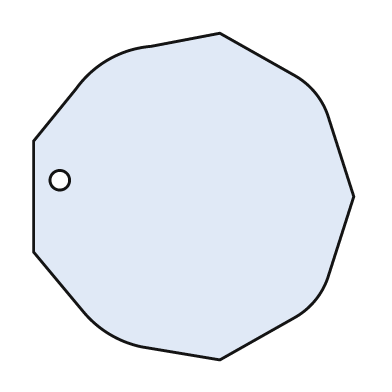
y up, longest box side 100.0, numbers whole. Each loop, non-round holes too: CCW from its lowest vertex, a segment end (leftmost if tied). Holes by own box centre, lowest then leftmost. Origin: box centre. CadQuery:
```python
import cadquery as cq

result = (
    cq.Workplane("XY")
    .moveTo(8.0, -50.0)
    .lineTo(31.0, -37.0)
    .threePointArc((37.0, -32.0), (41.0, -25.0))
    .lineTo(49.0, 0.0)
    .lineTo(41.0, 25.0)
    .threePointArc((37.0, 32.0), (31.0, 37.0))
    .lineTo(8.0, 50.0)
    .lineTo(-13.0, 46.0)
    .threePointArc((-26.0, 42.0), (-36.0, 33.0))
    .lineTo(-49.0, 17.0)
    .lineTo(-49.0, -17.0)
    .lineTo(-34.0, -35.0)
    .threePointArc((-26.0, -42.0), (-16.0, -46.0))
    .close()
    .moveTo(-41.0, 5.0)
    .circle(3.0)
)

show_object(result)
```